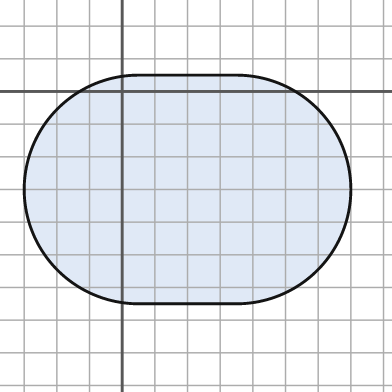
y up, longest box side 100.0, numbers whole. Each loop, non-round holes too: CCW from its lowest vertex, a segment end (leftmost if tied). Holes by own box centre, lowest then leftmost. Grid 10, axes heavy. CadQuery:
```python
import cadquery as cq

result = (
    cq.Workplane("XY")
    .moveTo(5.0, -65.0)
    .lineTo(35.0, -65.0)
    .threePointArc((70.0, -30.0), (35.0, 5.0))
    .lineTo(5.0, 5.0)
    .threePointArc((-30.0, -30.0), (5.0, -65.0))
    .close()
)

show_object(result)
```